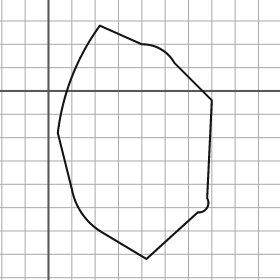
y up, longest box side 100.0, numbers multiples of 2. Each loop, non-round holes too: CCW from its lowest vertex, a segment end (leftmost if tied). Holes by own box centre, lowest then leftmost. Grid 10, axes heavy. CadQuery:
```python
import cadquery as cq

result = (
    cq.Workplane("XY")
    .moveTo(42.0, -72.0)
    .lineTo(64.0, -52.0)
    .threePointArc((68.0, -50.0), (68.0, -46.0))
    .lineTo(70.0, -4.0)
    .lineTo(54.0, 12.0)
    .threePointArc((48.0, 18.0), (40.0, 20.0))
    .lineTo(22.0, 28.0)
    .threePointArc((10.0, 6.0), (4.0, -18.0))
    .lineTo(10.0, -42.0)
    .threePointArc((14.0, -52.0), (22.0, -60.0))
    .close()
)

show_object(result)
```